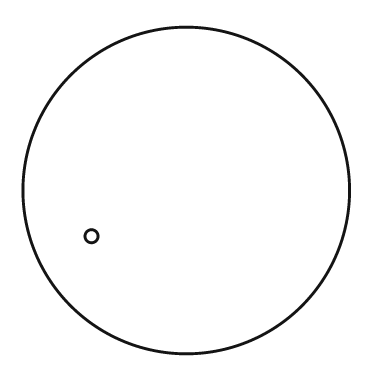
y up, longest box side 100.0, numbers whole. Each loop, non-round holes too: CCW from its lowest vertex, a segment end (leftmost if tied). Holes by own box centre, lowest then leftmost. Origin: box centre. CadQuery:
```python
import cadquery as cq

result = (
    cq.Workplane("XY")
    .moveTo(0.0, 0.0)
    .circle(50.0)
    .moveTo(-29.0, -14.0)
    .circle(2.0)
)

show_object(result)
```